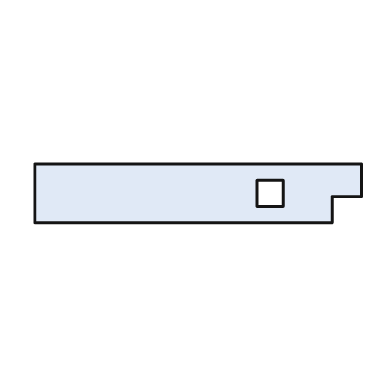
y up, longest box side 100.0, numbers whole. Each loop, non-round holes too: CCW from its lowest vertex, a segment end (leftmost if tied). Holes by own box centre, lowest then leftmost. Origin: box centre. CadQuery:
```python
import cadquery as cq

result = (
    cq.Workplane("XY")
    .moveTo(-50.0, -9.0)
    .lineTo(41.0, -9.0)
    .lineTo(41.0, -1.0)
    .lineTo(50.0, -1.0)
    .lineTo(50.0, 9.0)
    .lineTo(-50.0, 9.0)
    .close()
    .moveTo(18.0, -4.0)
    .lineTo(26.0, -4.0)
    .lineTo(26.0, 4.0)
    .lineTo(18.0, 4.0)
    .close()
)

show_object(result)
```